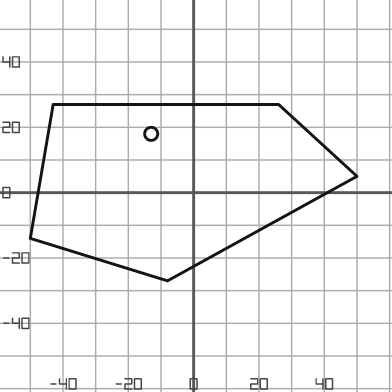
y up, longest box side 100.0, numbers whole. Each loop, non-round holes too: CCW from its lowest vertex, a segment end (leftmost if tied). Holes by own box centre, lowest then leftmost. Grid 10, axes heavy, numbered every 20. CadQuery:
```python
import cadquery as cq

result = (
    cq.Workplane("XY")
    .moveTo(-8.0, -27.0)
    .lineTo(50.0, 5.0)
    .lineTo(26.0, 27.0)
    .lineTo(-43.0, 27.0)
    .lineTo(-50.0, -14.0)
    .close()
    .moveTo(-13.0, 18.0)
    .circle(2.0)
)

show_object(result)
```